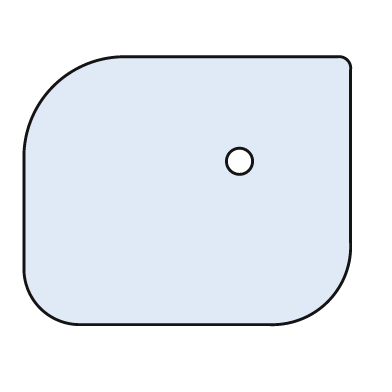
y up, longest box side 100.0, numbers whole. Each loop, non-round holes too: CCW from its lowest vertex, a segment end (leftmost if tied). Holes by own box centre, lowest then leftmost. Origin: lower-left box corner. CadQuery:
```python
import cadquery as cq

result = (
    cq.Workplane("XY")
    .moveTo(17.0, 0.0)
    .lineTo(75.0, 0.0)
    .threePointArc((93.0, 7.0), (100.0, 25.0))
    .lineTo(100.0, 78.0)
    .threePointArc((99.0, 81.0), (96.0, 82.0))
    .lineTo(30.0, 82.0)
    .threePointArc((9.0, 73.0), (0.0, 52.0))
    .lineTo(0.0, 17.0)
    .threePointArc((5.0, 5.0), (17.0, 0.0))
    .close()
    .moveTo(66.0, 50.0)
    .circle(4.0)
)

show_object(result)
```